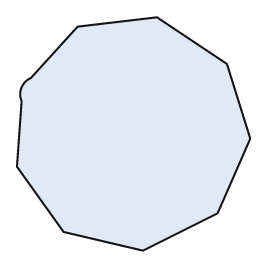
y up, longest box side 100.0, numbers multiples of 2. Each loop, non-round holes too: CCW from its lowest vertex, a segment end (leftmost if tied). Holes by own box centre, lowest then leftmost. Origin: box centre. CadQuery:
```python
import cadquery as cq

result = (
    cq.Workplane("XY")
    .moveTo(4.0, -50.0)
    .lineTo(36.0, -34.0)
    .lineTo(50.0, -2.0)
    .lineTo(40.0, 30.0)
    .lineTo(10.0, 50.0)
    .lineTo(-24.0, 46.0)
    .lineTo(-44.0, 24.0)
    .threePointArc((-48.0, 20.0), (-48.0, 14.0))
    .lineTo(-50.0, -14.0)
    .lineTo(-30.0, -42.0)
    .close()
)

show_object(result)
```